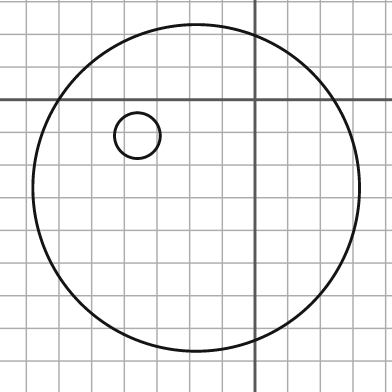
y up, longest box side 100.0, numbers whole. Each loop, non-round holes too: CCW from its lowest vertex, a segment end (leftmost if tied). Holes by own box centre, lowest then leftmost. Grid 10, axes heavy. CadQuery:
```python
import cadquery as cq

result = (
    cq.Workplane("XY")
    .moveTo(-18.0, -27.0)
    .circle(50.0)
    .moveTo(-36.0, -11.0)
    .circle(7.0)
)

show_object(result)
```